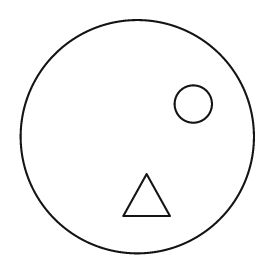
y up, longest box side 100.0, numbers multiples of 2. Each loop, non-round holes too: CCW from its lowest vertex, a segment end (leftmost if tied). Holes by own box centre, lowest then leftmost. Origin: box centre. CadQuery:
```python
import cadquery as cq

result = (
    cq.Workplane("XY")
    .moveTo(0.0, 0.0)
    .circle(50.0)
    .moveTo(-6.0, -34.0)
    .lineTo(14.0, -34.0)
    .lineTo(4.0, -16.0)
    .close()
    .moveTo(24.0, 14.0)
    .circle(8.0)
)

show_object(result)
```